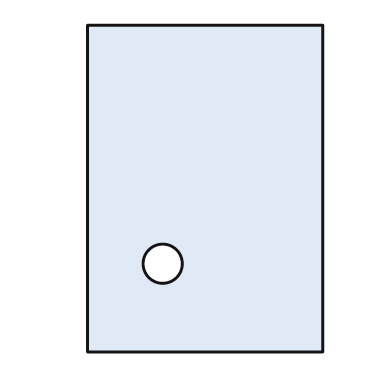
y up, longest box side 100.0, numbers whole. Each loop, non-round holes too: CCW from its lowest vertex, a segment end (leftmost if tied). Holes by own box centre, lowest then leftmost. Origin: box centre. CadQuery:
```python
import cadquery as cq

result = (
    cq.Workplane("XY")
    .moveTo(-36.0, -50.0)
    .lineTo(36.0, -50.0)
    .lineTo(36.0, 50.0)
    .lineTo(-36.0, 50.0)
    .close()
    .moveTo(-13.0, -23.0)
    .circle(6.0)
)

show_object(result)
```